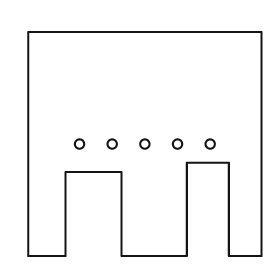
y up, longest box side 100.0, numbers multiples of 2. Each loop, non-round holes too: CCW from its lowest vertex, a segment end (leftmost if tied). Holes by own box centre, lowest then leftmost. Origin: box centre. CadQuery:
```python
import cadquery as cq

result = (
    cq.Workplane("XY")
    .moveTo(-50.0, -48.0)
    .lineTo(-34.0, -48.0)
    .lineTo(-34.0, -12.0)
    .lineTo(-10.0, -12.0)
    .lineTo(-10.0, -48.0)
    .lineTo(18.0, -48.0)
    .lineTo(18.0, -8.0)
    .lineTo(36.0, -8.0)
    .lineTo(36.0, -48.0)
    .lineTo(50.0, -48.0)
    .lineTo(50.0, 48.0)
    .lineTo(-50.0, 48.0)
    .close()
    .moveTo(-28.0, 0.0)
    .circle(2.0)
    .moveTo(-14.0, 0.0)
    .circle(2.0)
    .moveTo(0.0, 0.0)
    .circle(2.0)
    .moveTo(14.0, 0.0)
    .circle(2.0)
    .moveTo(28.0, 0.0)
    .circle(2.0)
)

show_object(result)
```